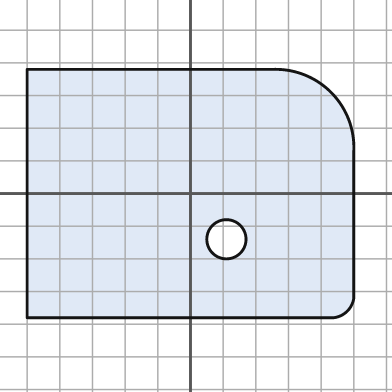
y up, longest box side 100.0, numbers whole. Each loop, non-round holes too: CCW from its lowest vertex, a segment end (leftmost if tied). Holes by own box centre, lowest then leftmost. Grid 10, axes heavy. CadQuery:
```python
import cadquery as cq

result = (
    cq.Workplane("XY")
    .moveTo(-50.0, -38.0)
    .lineTo(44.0, -38.0)
    .threePointArc((48.0, -36.0), (50.0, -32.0))
    .lineTo(50.0, 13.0)
    .threePointArc((43.0, 31.0), (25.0, 38.0))
    .lineTo(-50.0, 38.0)
    .close()
    .moveTo(11.0, -14.0)
    .circle(6.0)
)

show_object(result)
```